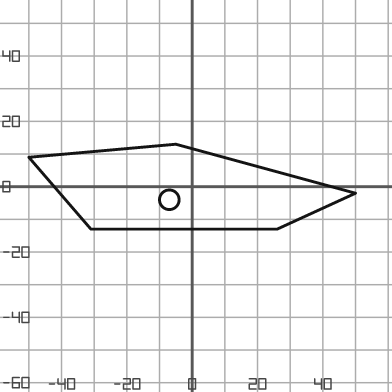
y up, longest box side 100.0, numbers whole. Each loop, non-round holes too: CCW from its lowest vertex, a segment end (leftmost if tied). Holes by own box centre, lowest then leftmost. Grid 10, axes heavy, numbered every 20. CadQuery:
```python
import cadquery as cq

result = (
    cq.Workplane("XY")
    .moveTo(-31.0, -13.0)
    .lineTo(26.0, -13.0)
    .lineTo(50.0, -2.0)
    .lineTo(-5.0, 13.0)
    .lineTo(-50.0, 9.0)
    .close()
    .moveTo(-7.0, -4.0)
    .circle(3.0)
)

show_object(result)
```